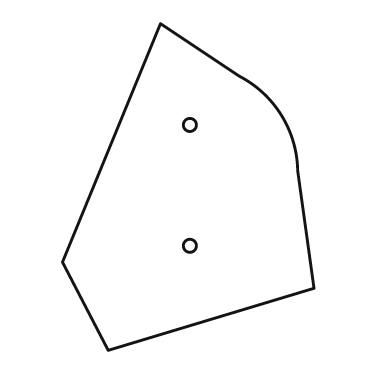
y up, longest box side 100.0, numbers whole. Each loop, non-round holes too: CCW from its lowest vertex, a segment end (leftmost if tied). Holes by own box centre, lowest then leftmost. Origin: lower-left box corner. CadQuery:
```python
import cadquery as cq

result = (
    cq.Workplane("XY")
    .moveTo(14.0, 0.0)
    .lineTo(77.0, 19.0)
    .lineTo(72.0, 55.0)
    .threePointArc((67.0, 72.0), (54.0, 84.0))
    .lineTo(30.0, 100.0)
    .lineTo(0.0, 27.0)
    .close()
    .moveTo(39.0, 32.0)
    .circle(2.0)
    .moveTo(39.0, 69.0)
    .circle(2.0)
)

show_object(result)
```